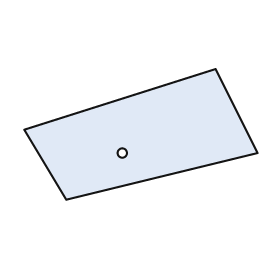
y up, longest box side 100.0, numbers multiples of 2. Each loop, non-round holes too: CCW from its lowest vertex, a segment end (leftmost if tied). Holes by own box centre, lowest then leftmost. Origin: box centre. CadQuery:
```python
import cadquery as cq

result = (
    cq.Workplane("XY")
    .moveTo(-32.0, -28.0)
    .lineTo(50.0, -8.0)
    .lineTo(32.0, 28.0)
    .lineTo(-50.0, 2.0)
    .close()
    .moveTo(-8.0, -8.0)
    .circle(2.0)
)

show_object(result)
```